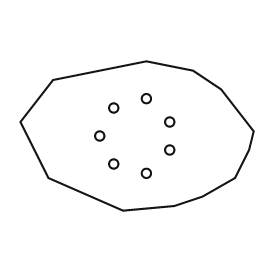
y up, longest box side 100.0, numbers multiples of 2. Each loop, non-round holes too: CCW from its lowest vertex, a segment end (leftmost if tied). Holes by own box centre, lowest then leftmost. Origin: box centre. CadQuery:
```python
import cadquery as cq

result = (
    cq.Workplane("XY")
    .moveTo(-6.0, -32.0)
    .lineTo(16.0, -30.0)
    .lineTo(28.0, -26.0)
    .lineTo(42.0, -18.0)
    .lineTo(48.0, -6.0)
    .lineTo(50.0, 2.0)
    .lineTo(36.0, 20.0)
    .lineTo(24.0, 28.0)
    .lineTo(4.0, 32.0)
    .lineTo(-36.0, 24.0)
    .lineTo(-50.0, 6.0)
    .lineTo(-38.0, -18.0)
    .close()
    .moveTo(4.0, -16.0)
    .circle(2.0)
    .moveTo(-10.0, -12.0)
    .circle(2.0)
    .moveTo(14.0, -6.0)
    .circle(2.0)
    .moveTo(-16.0, 0.0)
    .circle(2.0)
    .moveTo(14.0, 6.0)
    .circle(2.0)
    .moveTo(-10.0, 12.0)
    .circle(2.0)
    .moveTo(4.0, 16.0)
    .circle(2.0)
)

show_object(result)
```